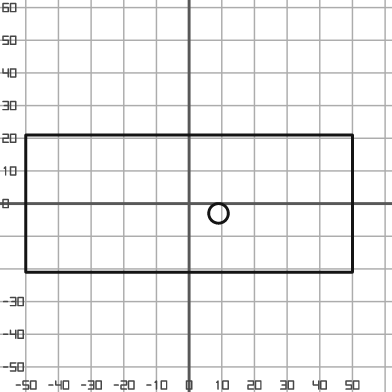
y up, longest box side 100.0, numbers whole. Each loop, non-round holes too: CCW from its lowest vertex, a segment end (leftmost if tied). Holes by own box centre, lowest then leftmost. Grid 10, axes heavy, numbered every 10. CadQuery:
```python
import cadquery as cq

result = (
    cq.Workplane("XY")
    .moveTo(-50.0, -21.0)
    .lineTo(50.0, -21.0)
    .lineTo(50.0, 21.0)
    .lineTo(-50.0, 21.0)
    .close()
    .moveTo(9.0, -3.0)
    .circle(3.0)
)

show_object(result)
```